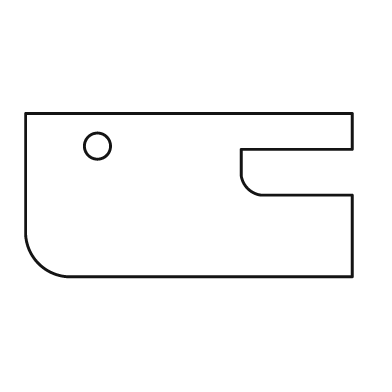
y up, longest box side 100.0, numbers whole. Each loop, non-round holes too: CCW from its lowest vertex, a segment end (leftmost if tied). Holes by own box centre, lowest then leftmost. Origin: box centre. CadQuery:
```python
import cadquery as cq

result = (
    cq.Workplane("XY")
    .moveTo(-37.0, -25.0)
    .lineTo(50.0, -25.0)
    .lineTo(50.0, 0.0)
    .lineTo(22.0, 0.0)
    .threePointArc((18.0, 2.0), (16.0, 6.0))
    .lineTo(16.0, 14.0)
    .lineTo(50.0, 14.0)
    .lineTo(50.0, 25.0)
    .lineTo(-50.0, 25.0)
    .lineTo(-50.0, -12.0)
    .threePointArc((-46.0, -21.0), (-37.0, -25.0))
    .close()
    .moveTo(-28.0, 15.0)
    .circle(4.0)
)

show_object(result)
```